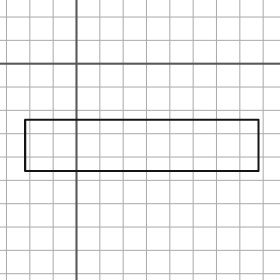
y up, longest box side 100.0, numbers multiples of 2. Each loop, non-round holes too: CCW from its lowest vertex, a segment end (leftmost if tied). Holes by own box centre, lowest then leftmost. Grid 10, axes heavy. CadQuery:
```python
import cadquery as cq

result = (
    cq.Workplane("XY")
    .moveTo(-22.0, -46.0)
    .lineTo(78.0, -46.0)
    .lineTo(78.0, -24.0)
    .lineTo(-22.0, -24.0)
    .close()
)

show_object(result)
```